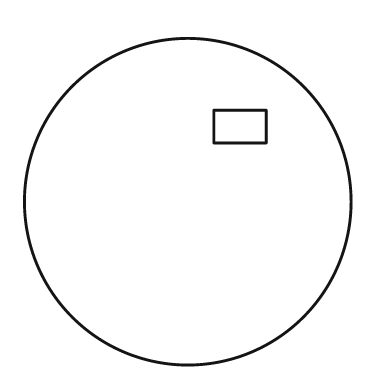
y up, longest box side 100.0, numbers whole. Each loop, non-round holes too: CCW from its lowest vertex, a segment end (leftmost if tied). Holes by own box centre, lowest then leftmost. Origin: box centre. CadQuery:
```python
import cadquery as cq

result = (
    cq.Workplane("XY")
    .moveTo(0.0, 0.0)
    .circle(50.0)
    .moveTo(8.0, 18.0)
    .lineTo(24.0, 18.0)
    .lineTo(24.0, 28.0)
    .lineTo(8.0, 28.0)
    .close()
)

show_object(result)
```